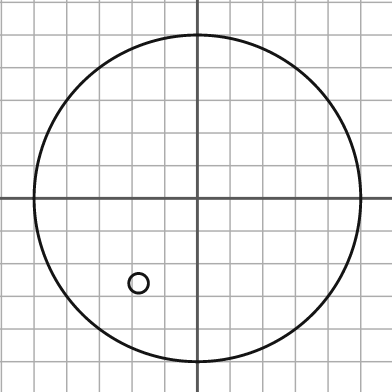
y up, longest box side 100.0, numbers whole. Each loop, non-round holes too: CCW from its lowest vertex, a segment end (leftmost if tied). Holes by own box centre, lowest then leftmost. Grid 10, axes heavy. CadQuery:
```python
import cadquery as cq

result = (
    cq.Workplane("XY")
    .moveTo(0.0, 0.0)
    .circle(50.0)
    .moveTo(-18.0, -26.0)
    .circle(3.0)
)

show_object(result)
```